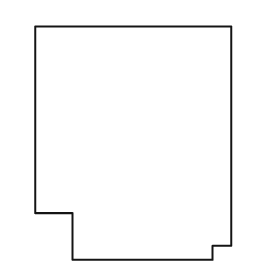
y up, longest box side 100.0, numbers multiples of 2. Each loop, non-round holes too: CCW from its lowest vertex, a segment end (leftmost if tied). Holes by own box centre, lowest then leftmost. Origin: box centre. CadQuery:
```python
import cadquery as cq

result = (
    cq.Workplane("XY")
    .moveTo(-26.0, -50.0)
    .lineTo(34.0, -50.0)
    .lineTo(34.0, -44.0)
    .lineTo(42.0, -44.0)
    .lineTo(42.0, 50.0)
    .lineTo(-42.0, 50.0)
    .lineTo(-42.0, -30.0)
    .lineTo(-26.0, -30.0)
    .close()
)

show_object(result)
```